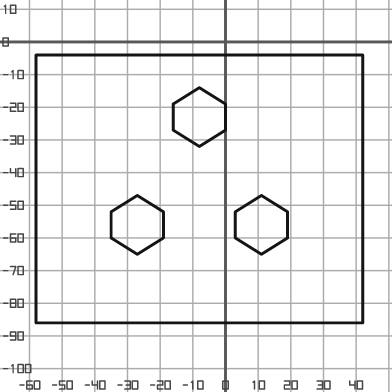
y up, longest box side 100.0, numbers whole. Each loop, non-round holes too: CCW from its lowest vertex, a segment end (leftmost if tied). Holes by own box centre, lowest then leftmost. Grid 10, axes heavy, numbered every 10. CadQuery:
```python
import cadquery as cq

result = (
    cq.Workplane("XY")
    .moveTo(-58.0, -86.0)
    .lineTo(42.0, -86.0)
    .lineTo(42.0, -4.0)
    .lineTo(-58.0, -4.0)
    .close()
    .moveTo(-27.0, -65.0)
    .lineTo(-19.0, -60.0)
    .lineTo(-19.0, -52.0)
    .lineTo(-27.0, -47.0)
    .lineTo(-35.0, -52.0)
    .lineTo(-35.0, -60.0)
    .close()
    .moveTo(11.0, -65.0)
    .lineTo(19.0, -60.0)
    .lineTo(19.0, -52.0)
    .lineTo(11.0, -47.0)
    .lineTo(3.0, -52.0)
    .lineTo(3.0, -60.0)
    .close()
    .moveTo(-8.0, -32.0)
    .lineTo(0.0, -27.0)
    .lineTo(0.0, -19.0)
    .lineTo(-8.0, -14.0)
    .lineTo(-16.0, -19.0)
    .lineTo(-16.0, -27.0)
    .close()
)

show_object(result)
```